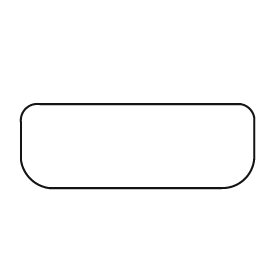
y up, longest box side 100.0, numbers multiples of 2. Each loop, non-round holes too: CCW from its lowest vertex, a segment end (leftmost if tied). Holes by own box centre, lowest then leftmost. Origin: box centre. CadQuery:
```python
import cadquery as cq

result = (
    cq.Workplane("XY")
    .moveTo(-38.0, -18.0)
    .lineTo(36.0, -18.0)
    .threePointArc((46.0, -14.0), (50.0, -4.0))
    .lineTo(50.0, 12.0)
    .threePointArc((48.0, 16.0), (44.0, 18.0))
    .lineTo(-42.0, 18.0)
    .threePointArc((-48.0, 16.0), (-50.0, 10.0))
    .lineTo(-50.0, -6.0)
    .threePointArc((-46.0, -14.0), (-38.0, -18.0))
    .close()
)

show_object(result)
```